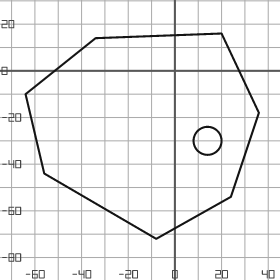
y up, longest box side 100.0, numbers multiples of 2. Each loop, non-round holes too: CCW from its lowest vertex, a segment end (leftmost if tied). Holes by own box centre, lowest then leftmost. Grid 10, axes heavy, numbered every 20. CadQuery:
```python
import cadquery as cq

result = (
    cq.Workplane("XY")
    .moveTo(-8.0, -72.0)
    .lineTo(24.0, -54.0)
    .lineTo(36.0, -18.0)
    .lineTo(20.0, 16.0)
    .lineTo(-34.0, 14.0)
    .lineTo(-64.0, -10.0)
    .lineTo(-56.0, -44.0)
    .close()
    .moveTo(14.0, -30.0)
    .circle(6.0)
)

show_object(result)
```